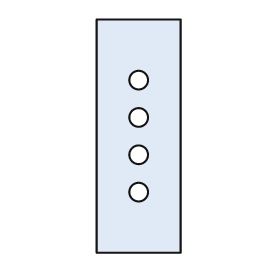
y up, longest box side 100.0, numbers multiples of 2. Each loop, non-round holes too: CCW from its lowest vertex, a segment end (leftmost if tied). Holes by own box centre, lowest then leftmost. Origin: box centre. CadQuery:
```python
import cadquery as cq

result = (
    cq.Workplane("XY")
    .moveTo(-18.0, -50.0)
    .lineTo(18.0, -50.0)
    .lineTo(18.0, 50.0)
    .lineTo(-18.0, 50.0)
    .close()
    .moveTo(0.0, -24.0)
    .circle(4.0)
    .moveTo(0.0, -8.0)
    .circle(4.0)
    .moveTo(0.0, 8.0)
    .circle(4.0)
    .moveTo(0.0, 24.0)
    .circle(4.0)
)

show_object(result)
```